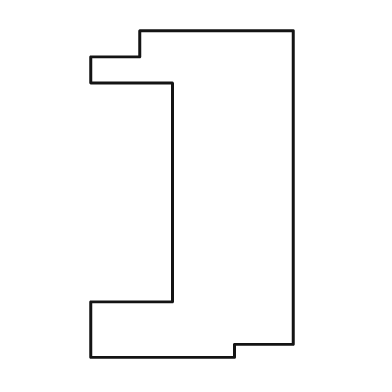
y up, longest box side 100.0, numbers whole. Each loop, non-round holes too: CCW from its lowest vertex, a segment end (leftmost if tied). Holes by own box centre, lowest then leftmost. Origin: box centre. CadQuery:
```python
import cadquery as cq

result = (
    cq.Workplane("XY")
    .moveTo(-31.0, -50.0)
    .lineTo(13.0, -50.0)
    .lineTo(13.0, -46.0)
    .lineTo(31.0, -46.0)
    .lineTo(31.0, 50.0)
    .lineTo(-16.0, 50.0)
    .lineTo(-16.0, 42.0)
    .lineTo(-31.0, 42.0)
    .lineTo(-31.0, 34.0)
    .lineTo(-6.0, 34.0)
    .lineTo(-6.0, -33.0)
    .lineTo(-31.0, -33.0)
    .close()
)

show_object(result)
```